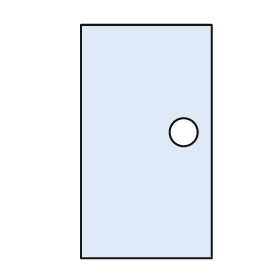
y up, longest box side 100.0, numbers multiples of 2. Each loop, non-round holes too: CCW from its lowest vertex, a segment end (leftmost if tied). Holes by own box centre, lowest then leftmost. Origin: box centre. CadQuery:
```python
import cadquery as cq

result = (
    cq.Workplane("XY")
    .moveTo(-28.0, -50.0)
    .lineTo(28.0, -50.0)
    .lineTo(28.0, 50.0)
    .lineTo(-28.0, 50.0)
    .close()
    .moveTo(16.0, 4.0)
    .circle(6.0)
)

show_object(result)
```